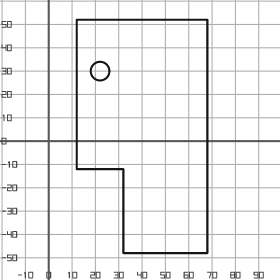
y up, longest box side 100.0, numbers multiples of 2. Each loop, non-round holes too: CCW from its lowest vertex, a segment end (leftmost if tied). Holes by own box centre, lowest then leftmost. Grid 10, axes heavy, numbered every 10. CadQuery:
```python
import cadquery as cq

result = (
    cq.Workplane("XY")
    .moveTo(32.0, -48.0)
    .lineTo(68.0, -48.0)
    .lineTo(68.0, 52.0)
    .lineTo(12.0, 52.0)
    .lineTo(12.0, -12.0)
    .lineTo(32.0, -12.0)
    .close()
    .moveTo(22.0, 30.0)
    .circle(4.0)
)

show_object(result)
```